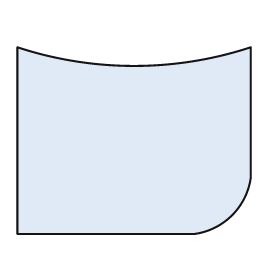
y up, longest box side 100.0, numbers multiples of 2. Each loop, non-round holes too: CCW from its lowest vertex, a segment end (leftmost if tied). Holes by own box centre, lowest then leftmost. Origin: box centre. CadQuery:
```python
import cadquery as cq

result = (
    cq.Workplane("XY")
    .moveTo(-50.0, -40.0)
    .lineTo(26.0, -40.0)
    .threePointArc((42.0, -32.0), (50.0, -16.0))
    .lineTo(50.0, 40.0)
    .threePointArc((0.0, 32.0), (-50.0, 40.0))
    .close()
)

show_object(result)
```